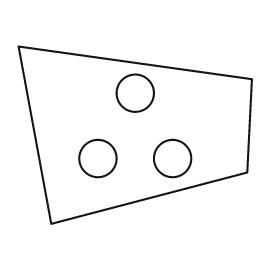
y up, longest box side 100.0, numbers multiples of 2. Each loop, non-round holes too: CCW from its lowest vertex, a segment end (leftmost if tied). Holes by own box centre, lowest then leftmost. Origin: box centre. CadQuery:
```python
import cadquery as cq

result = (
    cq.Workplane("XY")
    .moveTo(-36.0, -38.0)
    .lineTo(48.0, -16.0)
    .lineTo(50.0, 24.0)
    .lineTo(-50.0, 38.0)
    .close()
    .moveTo(-16.0, -10.0)
    .circle(8.0)
    .moveTo(16.0, -10.0)
    .circle(8.0)
    .moveTo(0.0, 18.0)
    .circle(8.0)
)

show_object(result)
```